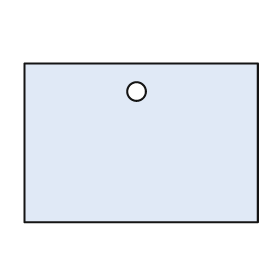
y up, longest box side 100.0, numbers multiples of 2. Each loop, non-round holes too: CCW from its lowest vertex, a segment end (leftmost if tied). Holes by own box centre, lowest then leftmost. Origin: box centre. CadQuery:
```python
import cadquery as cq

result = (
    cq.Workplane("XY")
    .moveTo(-50.0, -34.0)
    .lineTo(50.0, -34.0)
    .lineTo(50.0, 34.0)
    .lineTo(-50.0, 34.0)
    .close()
    .moveTo(-2.0, 22.0)
    .circle(4.0)
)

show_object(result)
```